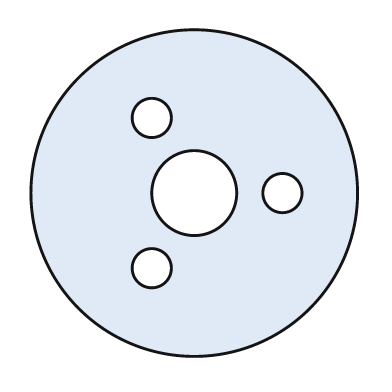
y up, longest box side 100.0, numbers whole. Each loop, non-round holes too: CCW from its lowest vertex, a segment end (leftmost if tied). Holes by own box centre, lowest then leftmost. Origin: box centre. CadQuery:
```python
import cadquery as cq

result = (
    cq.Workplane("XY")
    .moveTo(0.0, 0.0)
    .circle(50.0)
    .moveTo(-13.0, -23.0)
    .circle(6.0)
    .moveTo(0.0, 0.0)
    .circle(13.0)
    .moveTo(27.0, 0.0)
    .circle(6.0)
    .moveTo(-13.0, 23.0)
    .circle(6.0)
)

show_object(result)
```